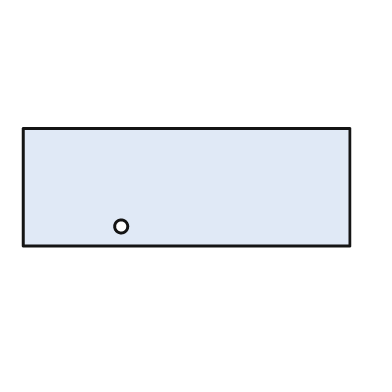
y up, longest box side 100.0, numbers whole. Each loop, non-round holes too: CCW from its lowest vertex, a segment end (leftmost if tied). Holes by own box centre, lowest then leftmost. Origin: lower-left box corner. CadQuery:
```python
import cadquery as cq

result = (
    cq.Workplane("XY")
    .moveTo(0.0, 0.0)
    .lineTo(100.0, 0.0)
    .lineTo(100.0, 36.0)
    .lineTo(0.0, 36.0)
    .close()
    .moveTo(30.0, 6.0)
    .circle(2.0)
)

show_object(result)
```